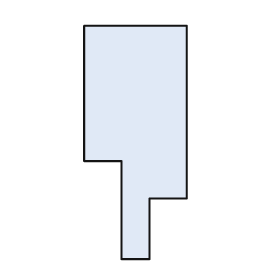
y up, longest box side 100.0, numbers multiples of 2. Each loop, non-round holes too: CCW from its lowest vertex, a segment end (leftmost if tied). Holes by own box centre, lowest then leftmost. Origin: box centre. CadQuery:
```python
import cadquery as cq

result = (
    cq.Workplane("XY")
    .moveTo(-6.0, -50.0)
    .lineTo(6.0, -50.0)
    .lineTo(6.0, -24.0)
    .lineTo(22.0, -24.0)
    .lineTo(22.0, 50.0)
    .lineTo(-22.0, 50.0)
    .lineTo(-22.0, -8.0)
    .lineTo(-6.0, -8.0)
    .close()
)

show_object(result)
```